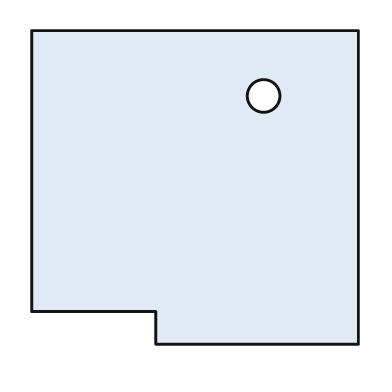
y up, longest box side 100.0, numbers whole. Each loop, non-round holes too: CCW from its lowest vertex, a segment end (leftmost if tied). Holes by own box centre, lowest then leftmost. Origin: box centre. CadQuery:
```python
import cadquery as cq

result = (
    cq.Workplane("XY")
    .moveTo(-12.0, -48.0)
    .lineTo(50.0, -48.0)
    .lineTo(50.0, 48.0)
    .lineTo(-50.0, 48.0)
    .lineTo(-50.0, -38.0)
    .lineTo(-12.0, -38.0)
    .close()
    .moveTo(21.0, 28.0)
    .circle(5.0)
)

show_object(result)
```